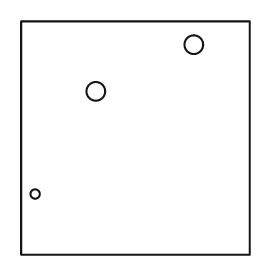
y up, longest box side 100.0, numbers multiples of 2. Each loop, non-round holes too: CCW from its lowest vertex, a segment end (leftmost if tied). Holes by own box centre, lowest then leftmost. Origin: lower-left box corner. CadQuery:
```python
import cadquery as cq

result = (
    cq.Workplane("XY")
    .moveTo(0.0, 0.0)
    .lineTo(98.0, 0.0)
    .lineTo(98.0, 100.0)
    .lineTo(0.0, 100.0)
    .close()
    .moveTo(6.0, 26.0)
    .circle(2.0)
    .moveTo(32.0, 70.0)
    .circle(4.0)
    .moveTo(74.0, 90.0)
    .circle(4.0)
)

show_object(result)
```